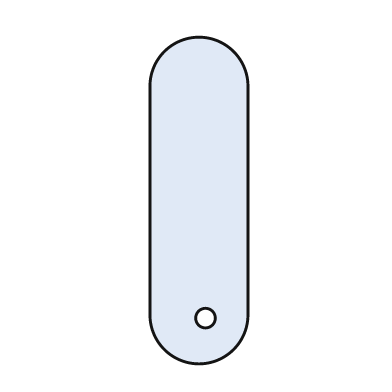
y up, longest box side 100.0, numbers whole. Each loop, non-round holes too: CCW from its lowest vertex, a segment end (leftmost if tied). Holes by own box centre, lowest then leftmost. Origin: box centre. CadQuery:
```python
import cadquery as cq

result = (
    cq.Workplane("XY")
    .moveTo(-15.0, -35.0)
    .threePointArc((0.0, -50.0), (15.0, -35.0))
    .lineTo(15.0, 35.0)
    .threePointArc((0.0, 50.0), (-15.0, 35.0))
    .close()
    .moveTo(2.0, -36.0)
    .circle(3.0)
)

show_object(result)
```